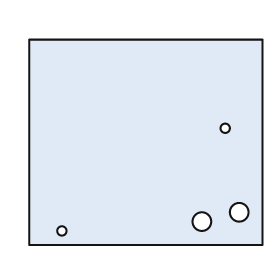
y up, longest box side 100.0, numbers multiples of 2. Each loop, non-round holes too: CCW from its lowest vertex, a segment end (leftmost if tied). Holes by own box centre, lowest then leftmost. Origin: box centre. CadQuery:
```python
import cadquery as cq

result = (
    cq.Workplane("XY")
    .moveTo(-50.0, -44.0)
    .lineTo(50.0, -44.0)
    .lineTo(50.0, 44.0)
    .lineTo(-50.0, 44.0)
    .close()
    .moveTo(-36.0, -38.0)
    .circle(2.0)
    .moveTo(24.0, -34.0)
    .circle(4.0)
    .moveTo(40.0, -30.0)
    .circle(4.0)
    .moveTo(34.0, 6.0)
    .circle(2.0)
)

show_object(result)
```